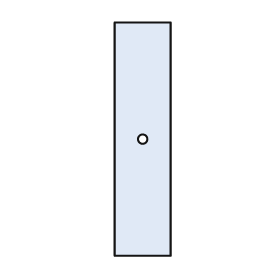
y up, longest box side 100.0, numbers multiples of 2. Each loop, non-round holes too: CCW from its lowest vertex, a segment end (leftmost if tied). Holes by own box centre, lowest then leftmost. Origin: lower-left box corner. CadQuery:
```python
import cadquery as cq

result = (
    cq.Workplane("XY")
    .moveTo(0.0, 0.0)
    .lineTo(24.0, 0.0)
    .lineTo(24.0, 100.0)
    .lineTo(0.0, 100.0)
    .close()
    .moveTo(12.0, 50.0)
    .circle(2.0)
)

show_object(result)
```